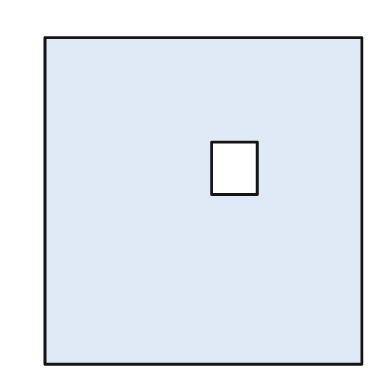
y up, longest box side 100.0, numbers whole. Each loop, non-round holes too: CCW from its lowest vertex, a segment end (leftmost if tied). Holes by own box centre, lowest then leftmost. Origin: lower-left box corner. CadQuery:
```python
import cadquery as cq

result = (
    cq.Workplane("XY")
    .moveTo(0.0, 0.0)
    .lineTo(97.0, 0.0)
    .lineTo(97.0, 100.0)
    .lineTo(0.0, 100.0)
    .close()
    .moveTo(51.0, 52.0)
    .lineTo(65.0, 52.0)
    .lineTo(65.0, 68.0)
    .lineTo(51.0, 68.0)
    .close()
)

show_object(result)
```